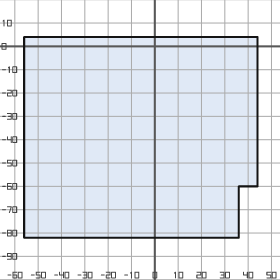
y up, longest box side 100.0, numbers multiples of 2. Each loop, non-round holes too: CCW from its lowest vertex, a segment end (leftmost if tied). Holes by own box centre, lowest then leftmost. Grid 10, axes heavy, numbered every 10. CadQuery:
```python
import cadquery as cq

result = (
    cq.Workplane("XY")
    .moveTo(-56.0, -82.0)
    .lineTo(36.0, -82.0)
    .lineTo(36.0, -60.0)
    .lineTo(44.0, -60.0)
    .lineTo(44.0, 4.0)
    .lineTo(-56.0, 4.0)
    .close()
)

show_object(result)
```